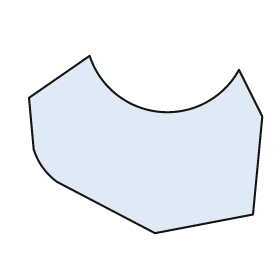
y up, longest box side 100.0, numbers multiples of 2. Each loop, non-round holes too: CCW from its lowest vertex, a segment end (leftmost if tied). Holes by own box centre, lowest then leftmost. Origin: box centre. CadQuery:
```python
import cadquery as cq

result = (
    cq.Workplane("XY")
    .moveTo(4.0, -38.0)
    .lineTo(46.0, -30.0)
    .lineTo(50.0, 12.0)
    .lineTo(40.0, 32.0)
    .threePointArc((6.0, 14.0), (-24.0, 38.0))
    .lineTo(-50.0, 20.0)
    .lineTo(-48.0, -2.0)
    .threePointArc((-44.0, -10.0), (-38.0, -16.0))
    .close()
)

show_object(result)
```